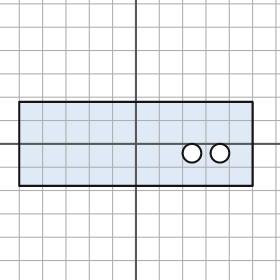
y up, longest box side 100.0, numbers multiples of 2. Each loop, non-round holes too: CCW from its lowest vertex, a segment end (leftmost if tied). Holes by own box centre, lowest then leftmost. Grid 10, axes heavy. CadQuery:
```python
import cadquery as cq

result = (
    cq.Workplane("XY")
    .moveTo(-50.0, -18.0)
    .lineTo(50.0, -18.0)
    .lineTo(50.0, 18.0)
    .lineTo(-50.0, 18.0)
    .close()
    .moveTo(24.0, -4.0)
    .circle(4.0)
    .moveTo(36.0, -4.0)
    .circle(4.0)
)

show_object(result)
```